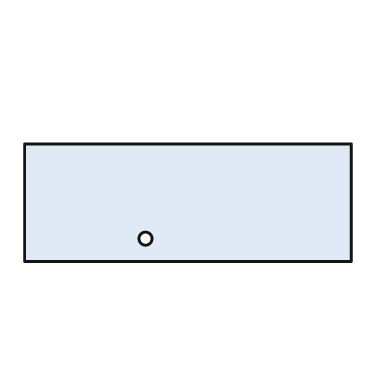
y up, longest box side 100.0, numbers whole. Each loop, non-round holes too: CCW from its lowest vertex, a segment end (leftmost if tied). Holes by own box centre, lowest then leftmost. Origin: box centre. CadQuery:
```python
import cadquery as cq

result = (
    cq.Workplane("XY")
    .moveTo(-50.0, -18.0)
    .lineTo(50.0, -18.0)
    .lineTo(50.0, 18.0)
    .lineTo(-50.0, 18.0)
    .close()
    .moveTo(-13.0, -11.0)
    .circle(2.0)
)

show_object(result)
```